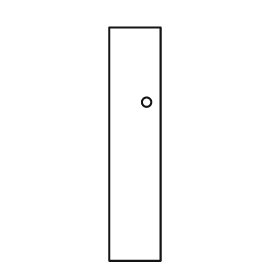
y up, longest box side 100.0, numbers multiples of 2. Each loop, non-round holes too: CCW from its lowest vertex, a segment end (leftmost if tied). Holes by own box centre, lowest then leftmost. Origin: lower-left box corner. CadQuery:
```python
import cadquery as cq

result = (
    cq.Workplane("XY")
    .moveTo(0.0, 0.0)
    .lineTo(22.0, 0.0)
    .lineTo(22.0, 100.0)
    .lineTo(0.0, 100.0)
    .close()
    .moveTo(16.0, 68.0)
    .circle(2.0)
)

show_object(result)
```